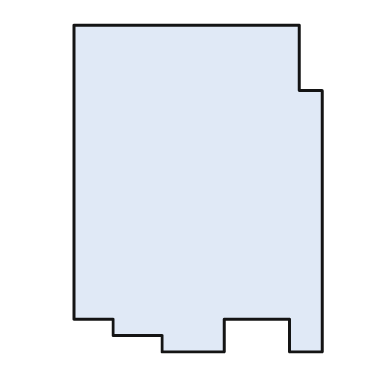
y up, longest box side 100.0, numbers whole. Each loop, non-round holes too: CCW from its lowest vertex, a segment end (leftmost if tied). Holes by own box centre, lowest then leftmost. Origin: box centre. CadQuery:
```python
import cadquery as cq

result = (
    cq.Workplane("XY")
    .moveTo(-11.0, -50.0)
    .lineTo(8.0, -50.0)
    .lineTo(8.0, -40.0)
    .lineTo(28.0, -40.0)
    .lineTo(28.0, -50.0)
    .lineTo(38.0, -50.0)
    .lineTo(38.0, 30.0)
    .lineTo(31.0, 30.0)
    .lineTo(31.0, 50.0)
    .lineTo(-38.0, 50.0)
    .lineTo(-38.0, -40.0)
    .lineTo(-26.0, -40.0)
    .lineTo(-26.0, -45.0)
    .lineTo(-11.0, -45.0)
    .close()
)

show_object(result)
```